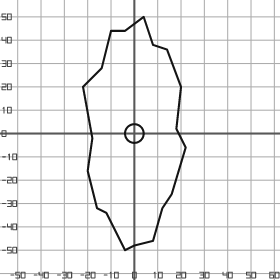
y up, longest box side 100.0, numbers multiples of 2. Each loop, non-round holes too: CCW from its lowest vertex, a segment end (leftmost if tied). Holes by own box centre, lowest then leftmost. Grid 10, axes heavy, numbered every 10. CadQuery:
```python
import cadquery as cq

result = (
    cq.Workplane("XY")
    .moveTo(-4.0, -50.0)
    .lineTo(0.0, -48.0)
    .lineTo(8.0, -46.0)
    .lineTo(12.0, -32.0)
    .lineTo(16.0, -26.0)
    .lineTo(22.0, -6.0)
    .lineTo(18.0, 2.0)
    .lineTo(20.0, 20.0)
    .lineTo(14.0, 36.0)
    .lineTo(8.0, 38.0)
    .lineTo(4.0, 50.0)
    .lineTo(-4.0, 44.0)
    .lineTo(-10.0, 44.0)
    .lineTo(-14.0, 28.0)
    .lineTo(-22.0, 20.0)
    .lineTo(-18.0, -2.0)
    .lineTo(-20.0, -16.0)
    .lineTo(-16.0, -32.0)
    .lineTo(-12.0, -34.0)
    .close()
    .moveTo(0.0, 0.0)
    .circle(4.0)
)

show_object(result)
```